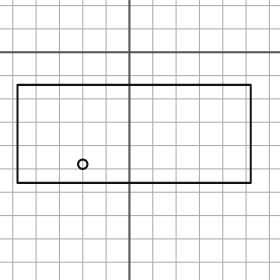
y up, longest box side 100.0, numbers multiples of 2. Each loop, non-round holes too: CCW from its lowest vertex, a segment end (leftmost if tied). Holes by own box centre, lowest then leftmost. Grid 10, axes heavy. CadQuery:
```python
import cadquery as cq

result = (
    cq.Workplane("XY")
    .moveTo(-48.0, -56.0)
    .lineTo(52.0, -56.0)
    .lineTo(52.0, -14.0)
    .lineTo(-48.0, -14.0)
    .close()
    .moveTo(-20.0, -48.0)
    .circle(2.0)
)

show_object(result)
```